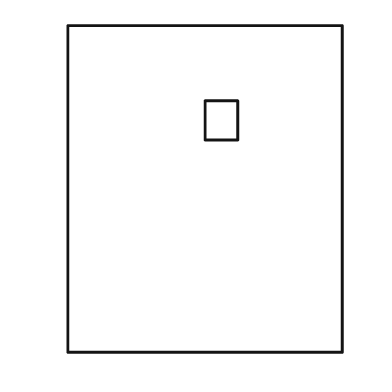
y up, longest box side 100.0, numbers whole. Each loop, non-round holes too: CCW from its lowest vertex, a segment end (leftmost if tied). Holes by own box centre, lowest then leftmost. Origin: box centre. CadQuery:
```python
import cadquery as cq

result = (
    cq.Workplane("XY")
    .moveTo(-42.0, -50.0)
    .lineTo(42.0, -50.0)
    .lineTo(42.0, 50.0)
    .lineTo(-42.0, 50.0)
    .close()
    .moveTo(0.0, 15.0)
    .lineTo(10.0, 15.0)
    .lineTo(10.0, 27.0)
    .lineTo(0.0, 27.0)
    .close()
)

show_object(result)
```